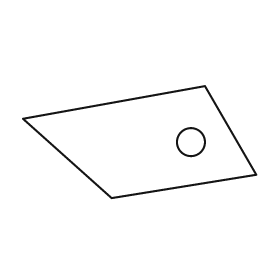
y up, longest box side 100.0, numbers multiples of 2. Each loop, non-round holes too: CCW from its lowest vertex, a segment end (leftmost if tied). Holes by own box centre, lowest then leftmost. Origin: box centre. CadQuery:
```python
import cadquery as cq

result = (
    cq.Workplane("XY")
    .moveTo(-12.0, -24.0)
    .lineTo(50.0, -14.0)
    .lineTo(28.0, 24.0)
    .lineTo(-50.0, 10.0)
    .close()
    .moveTo(22.0, 0.0)
    .circle(6.0)
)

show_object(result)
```